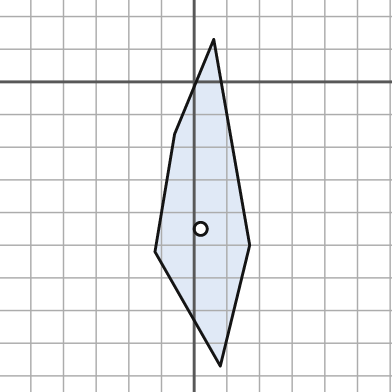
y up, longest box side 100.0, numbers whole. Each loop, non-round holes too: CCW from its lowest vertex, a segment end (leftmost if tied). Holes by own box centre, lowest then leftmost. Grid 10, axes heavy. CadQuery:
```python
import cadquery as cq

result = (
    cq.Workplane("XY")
    .moveTo(8.0, -87.0)
    .lineTo(17.0, -50.0)
    .lineTo(6.0, 13.0)
    .lineTo(-6.0, -16.0)
    .lineTo(-12.0, -52.0)
    .close()
    .moveTo(2.0, -45.0)
    .circle(2.0)
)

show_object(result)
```